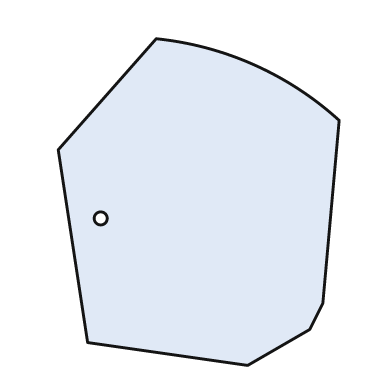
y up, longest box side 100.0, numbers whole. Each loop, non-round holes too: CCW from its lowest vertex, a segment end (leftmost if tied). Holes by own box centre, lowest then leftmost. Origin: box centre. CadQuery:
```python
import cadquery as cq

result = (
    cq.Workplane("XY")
    .moveTo(15.0, -50.0)
    .lineTo(34.0, -39.0)
    .lineTo(38.0, -31.0)
    .lineTo(43.0, 25.0)
    .threePointArc((17.0, 42.0), (-13.0, 50.0))
    .lineTo(-43.0, 16.0)
    .lineTo(-34.0, -43.0)
    .close()
    .moveTo(-30.0, -5.0)
    .circle(2.0)
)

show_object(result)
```